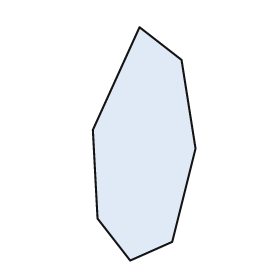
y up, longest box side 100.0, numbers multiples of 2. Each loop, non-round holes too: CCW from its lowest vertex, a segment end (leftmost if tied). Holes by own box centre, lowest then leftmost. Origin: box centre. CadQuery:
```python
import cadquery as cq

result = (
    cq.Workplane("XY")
    .moveTo(-6.0, -50.0)
    .lineTo(12.0, -42.0)
    .lineTo(22.0, -2.0)
    .lineTo(16.0, 36.0)
    .lineTo(-2.0, 50.0)
    .lineTo(-22.0, 6.0)
    .lineTo(-20.0, -32.0)
    .close()
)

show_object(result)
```